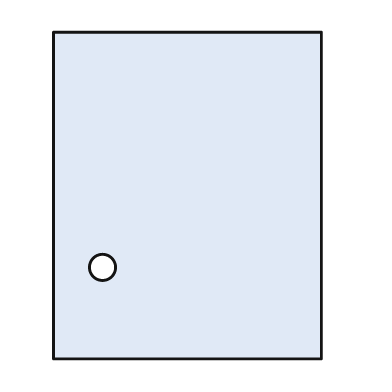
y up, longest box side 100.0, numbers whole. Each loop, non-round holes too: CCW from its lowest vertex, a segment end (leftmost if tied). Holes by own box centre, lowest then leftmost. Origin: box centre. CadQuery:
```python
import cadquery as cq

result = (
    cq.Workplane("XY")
    .moveTo(-41.0, -50.0)
    .lineTo(41.0, -50.0)
    .lineTo(41.0, 50.0)
    .lineTo(-41.0, 50.0)
    .close()
    .moveTo(-26.0, -22.0)
    .circle(4.0)
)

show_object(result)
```